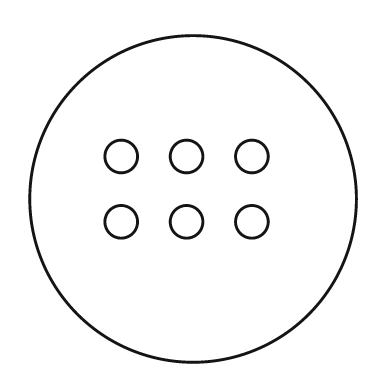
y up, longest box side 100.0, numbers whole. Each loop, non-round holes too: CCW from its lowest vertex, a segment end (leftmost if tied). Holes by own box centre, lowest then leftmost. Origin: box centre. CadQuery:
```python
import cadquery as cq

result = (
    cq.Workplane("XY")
    .moveTo(0.0, 0.0)
    .circle(50.0)
    .moveTo(-22.0, -7.0)
    .circle(5.0)
    .moveTo(-2.0, -7.0)
    .circle(5.0)
    .moveTo(18.0, -7.0)
    .circle(5.0)
    .moveTo(-22.0, 13.0)
    .circle(5.0)
    .moveTo(-2.0, 13.0)
    .circle(5.0)
    .moveTo(18.0, 13.0)
    .circle(5.0)
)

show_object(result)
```